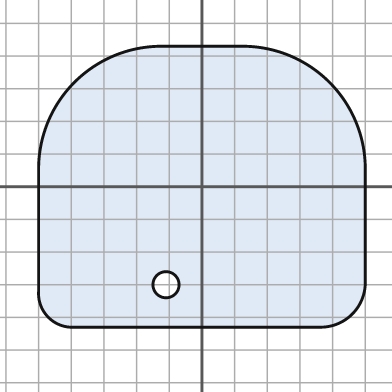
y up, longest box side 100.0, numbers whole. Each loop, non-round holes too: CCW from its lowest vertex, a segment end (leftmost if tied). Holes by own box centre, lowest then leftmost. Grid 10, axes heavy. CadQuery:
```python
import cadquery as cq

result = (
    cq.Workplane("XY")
    .moveTo(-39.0, -43.0)
    .lineTo(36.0, -43.0)
    .threePointArc((46.0, -39.0), (50.0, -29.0))
    .lineTo(50.0, 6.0)
    .threePointArc((39.0, 32.0), (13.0, 43.0))
    .lineTo(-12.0, 43.0)
    .threePointArc((-39.0, 32.0), (-50.0, 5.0))
    .lineTo(-50.0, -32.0)
    .threePointArc((-47.0, -40.0), (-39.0, -43.0))
    .close()
    .moveTo(-11.0, -30.0)
    .circle(4.0)
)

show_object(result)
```